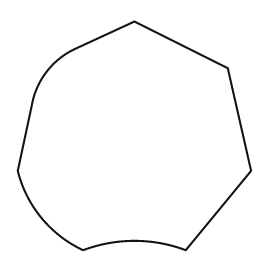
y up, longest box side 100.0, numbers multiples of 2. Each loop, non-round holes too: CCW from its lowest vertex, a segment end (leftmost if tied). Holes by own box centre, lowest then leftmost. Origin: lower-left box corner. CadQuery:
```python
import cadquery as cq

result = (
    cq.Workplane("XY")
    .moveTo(28.0, 0.0)
    .threePointArc((50.0, 4.0), (72.0, 0.0))
    .lineTo(100.0, 34.0)
    .lineTo(90.0, 78.0)
    .lineTo(50.0, 98.0)
    .lineTo(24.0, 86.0)
    .threePointArc((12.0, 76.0), (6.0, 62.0))
    .lineTo(0.0, 34.0)
    .threePointArc((10.0, 14.0), (28.0, 0.0))
    .close()
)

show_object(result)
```